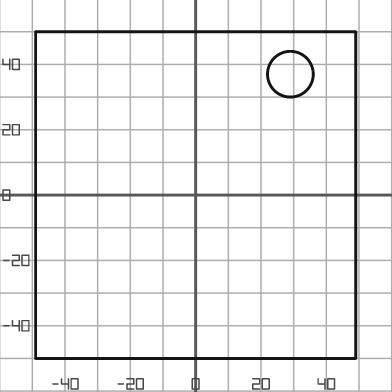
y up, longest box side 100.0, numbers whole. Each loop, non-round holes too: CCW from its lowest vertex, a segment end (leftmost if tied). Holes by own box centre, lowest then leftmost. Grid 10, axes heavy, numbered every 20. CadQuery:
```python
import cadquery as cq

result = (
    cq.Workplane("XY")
    .moveTo(-49.0, -50.0)
    .lineTo(49.0, -50.0)
    .lineTo(49.0, 50.0)
    .lineTo(-49.0, 50.0)
    .close()
    .moveTo(29.0, 37.0)
    .circle(7.0)
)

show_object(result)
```